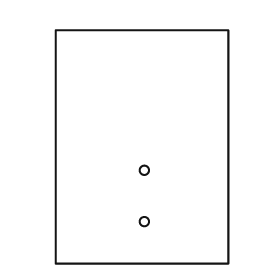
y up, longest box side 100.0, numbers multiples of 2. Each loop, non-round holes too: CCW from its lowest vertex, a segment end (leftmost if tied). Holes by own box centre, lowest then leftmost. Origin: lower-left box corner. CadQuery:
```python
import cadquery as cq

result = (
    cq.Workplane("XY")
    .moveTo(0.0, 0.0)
    .lineTo(74.0, 0.0)
    .lineTo(74.0, 100.0)
    .lineTo(0.0, 100.0)
    .close()
    .moveTo(38.0, 18.0)
    .circle(2.0)
    .moveTo(38.0, 40.0)
    .circle(2.0)
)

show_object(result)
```